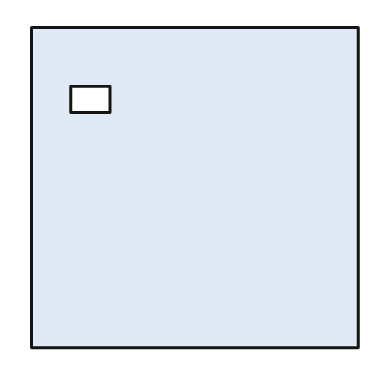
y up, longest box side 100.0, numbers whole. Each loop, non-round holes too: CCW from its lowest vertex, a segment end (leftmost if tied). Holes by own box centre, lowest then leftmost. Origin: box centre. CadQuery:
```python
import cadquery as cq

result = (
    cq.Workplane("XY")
    .moveTo(-50.0, -49.0)
    .lineTo(50.0, -49.0)
    .lineTo(50.0, 49.0)
    .lineTo(-50.0, 49.0)
    .close()
    .moveTo(-38.0, 23.0)
    .lineTo(-26.0, 23.0)
    .lineTo(-26.0, 31.0)
    .lineTo(-38.0, 31.0)
    .close()
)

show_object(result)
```